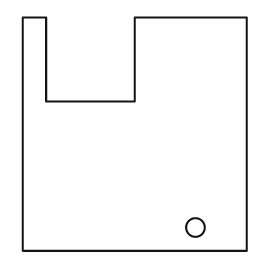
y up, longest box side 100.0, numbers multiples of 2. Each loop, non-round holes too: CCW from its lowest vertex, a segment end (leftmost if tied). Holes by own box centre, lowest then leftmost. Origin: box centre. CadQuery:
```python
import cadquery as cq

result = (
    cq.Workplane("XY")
    .moveTo(-48.0, -50.0)
    .lineTo(48.0, -50.0)
    .lineTo(48.0, 50.0)
    .lineTo(0.0, 50.0)
    .lineTo(0.0, 14.0)
    .lineTo(-38.0, 14.0)
    .lineTo(-38.0, 50.0)
    .lineTo(-48.0, 50.0)
    .close()
    .moveTo(26.0, -40.0)
    .circle(4.0)
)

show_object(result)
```